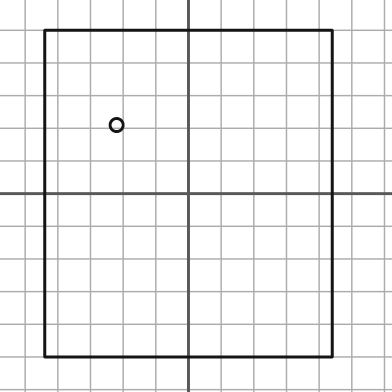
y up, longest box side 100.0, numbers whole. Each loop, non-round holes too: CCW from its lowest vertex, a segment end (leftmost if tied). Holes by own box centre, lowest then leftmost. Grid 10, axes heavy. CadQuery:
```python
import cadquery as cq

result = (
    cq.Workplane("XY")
    .moveTo(-44.0, -50.0)
    .lineTo(44.0, -50.0)
    .lineTo(44.0, 50.0)
    .lineTo(-44.0, 50.0)
    .close()
    .moveTo(-22.0, 21.0)
    .circle(2.0)
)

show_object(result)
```